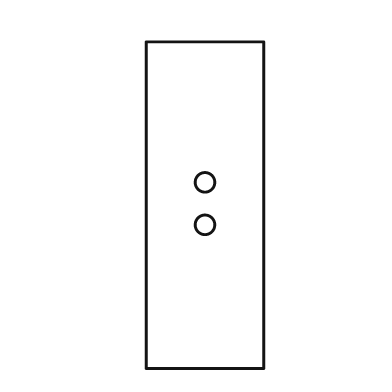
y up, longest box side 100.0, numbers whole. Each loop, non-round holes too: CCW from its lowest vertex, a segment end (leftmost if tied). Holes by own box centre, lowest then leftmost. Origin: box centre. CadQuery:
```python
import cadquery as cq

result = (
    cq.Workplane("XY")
    .moveTo(-18.0, -50.0)
    .lineTo(18.0, -50.0)
    .lineTo(18.0, 50.0)
    .lineTo(-18.0, 50.0)
    .close()
    .moveTo(0.0, -6.0)
    .circle(3.0)
    .moveTo(0.0, 7.0)
    .circle(3.0)
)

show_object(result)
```